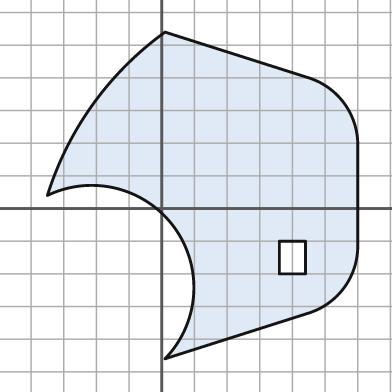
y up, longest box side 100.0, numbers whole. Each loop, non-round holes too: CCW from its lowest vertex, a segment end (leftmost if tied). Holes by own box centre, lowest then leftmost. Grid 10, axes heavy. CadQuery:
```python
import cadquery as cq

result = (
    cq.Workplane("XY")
    .moveTo(1.0, -46.0)
    .lineTo(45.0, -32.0)
    .threePointArc((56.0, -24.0), (60.0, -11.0))
    .lineTo(60.0, 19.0)
    .threePointArc((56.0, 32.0), (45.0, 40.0))
    .lineTo(1.0, 54.0)
    .threePointArc((-21.0, 32.0), (-35.0, 4.0))
    .threePointArc((4.0, -6.0), (1.0, -46.0))
    .close()
    .moveTo(36.0, -20.0)
    .lineTo(44.0, -20.0)
    .lineTo(44.0, -10.0)
    .lineTo(36.0, -10.0)
    .close()
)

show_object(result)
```